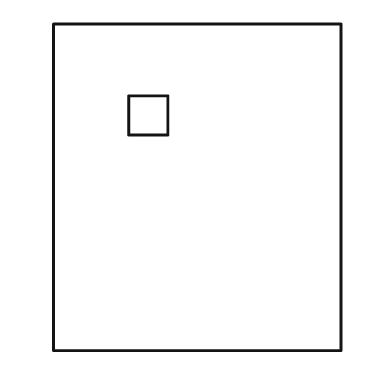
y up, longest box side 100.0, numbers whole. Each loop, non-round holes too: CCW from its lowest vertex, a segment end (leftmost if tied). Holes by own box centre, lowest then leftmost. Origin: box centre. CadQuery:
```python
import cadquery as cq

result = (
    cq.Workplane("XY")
    .moveTo(-44.0, -50.0)
    .lineTo(44.0, -50.0)
    .lineTo(44.0, 50.0)
    .lineTo(-44.0, 50.0)
    .close()
    .moveTo(-21.0, 16.0)
    .lineTo(-9.0, 16.0)
    .lineTo(-9.0, 28.0)
    .lineTo(-21.0, 28.0)
    .close()
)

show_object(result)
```